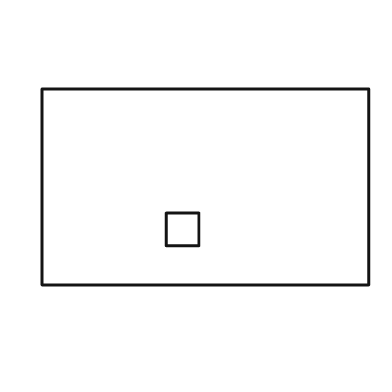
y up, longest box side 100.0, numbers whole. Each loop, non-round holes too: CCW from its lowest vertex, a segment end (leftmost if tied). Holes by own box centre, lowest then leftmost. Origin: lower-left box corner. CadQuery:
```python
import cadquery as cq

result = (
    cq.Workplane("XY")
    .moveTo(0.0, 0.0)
    .lineTo(100.0, 0.0)
    .lineTo(100.0, 60.0)
    .lineTo(0.0, 60.0)
    .close()
    .moveTo(38.0, 12.0)
    .lineTo(48.0, 12.0)
    .lineTo(48.0, 22.0)
    .lineTo(38.0, 22.0)
    .close()
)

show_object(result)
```